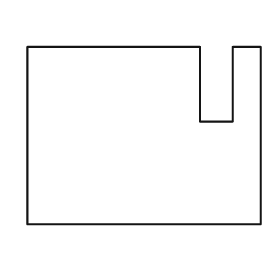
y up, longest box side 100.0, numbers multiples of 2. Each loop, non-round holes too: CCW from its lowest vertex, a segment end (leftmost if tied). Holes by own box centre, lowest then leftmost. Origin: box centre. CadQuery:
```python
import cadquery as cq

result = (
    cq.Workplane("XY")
    .moveTo(-50.0, -38.0)
    .lineTo(50.0, -38.0)
    .lineTo(50.0, 38.0)
    .lineTo(38.0, 38.0)
    .lineTo(38.0, 6.0)
    .lineTo(24.0, 6.0)
    .lineTo(24.0, 38.0)
    .lineTo(-50.0, 38.0)
    .close()
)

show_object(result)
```